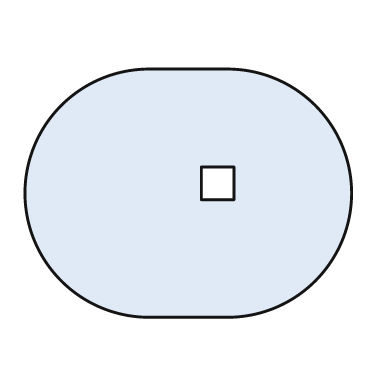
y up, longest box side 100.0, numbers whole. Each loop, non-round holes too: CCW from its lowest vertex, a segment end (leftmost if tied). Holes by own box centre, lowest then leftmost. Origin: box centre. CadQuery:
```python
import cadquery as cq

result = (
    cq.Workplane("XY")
    .moveTo(-12.0, -38.0)
    .lineTo(12.0, -38.0)
    .threePointArc((50.0, 0.0), (12.0, 38.0))
    .lineTo(-12.0, 38.0)
    .threePointArc((-50.0, 0.0), (-12.0, -38.0))
    .close()
    .moveTo(4.0, -2.0)
    .lineTo(14.0, -2.0)
    .lineTo(14.0, 8.0)
    .lineTo(4.0, 8.0)
    .close()
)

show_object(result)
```